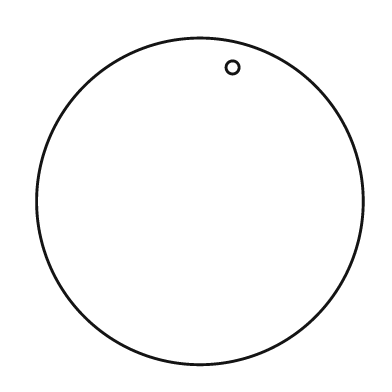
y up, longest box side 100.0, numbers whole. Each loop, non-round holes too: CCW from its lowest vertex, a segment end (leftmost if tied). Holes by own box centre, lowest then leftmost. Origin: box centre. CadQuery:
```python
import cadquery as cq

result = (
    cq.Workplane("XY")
    .moveTo(0.0, 0.0)
    .circle(50.0)
    .moveTo(10.0, 41.0)
    .circle(2.0)
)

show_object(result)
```